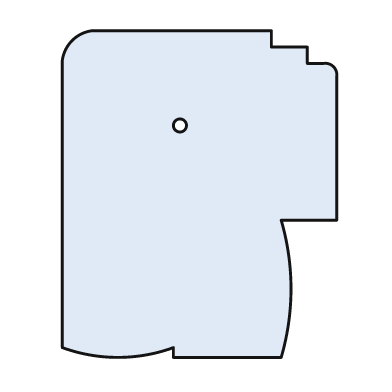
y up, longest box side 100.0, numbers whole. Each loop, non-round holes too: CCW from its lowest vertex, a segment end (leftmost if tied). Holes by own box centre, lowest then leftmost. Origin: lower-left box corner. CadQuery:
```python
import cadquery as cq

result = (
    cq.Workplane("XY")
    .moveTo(34.0, 0.0)
    .lineTo(67.0, 0.0)
    .threePointArc((70.0, 21.0), (67.0, 42.0))
    .lineTo(84.0, 42.0)
    .lineTo(84.0, 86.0)
    .threePointArc((83.0, 89.0), (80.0, 90.0))
    .lineTo(75.0, 90.0)
    .lineTo(75.0, 95.0)
    .lineTo(64.0, 95.0)
    .lineTo(64.0, 100.0)
    .lineTo(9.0, 100.0)
    .threePointArc((3.0, 97.0), (0.0, 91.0))
    .lineTo(0.0, 3.0)
    .threePointArc((17.0, 0.0), (34.0, 3.0))
    .close()
    .moveTo(36.0, 71.0)
    .circle(2.0)
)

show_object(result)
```